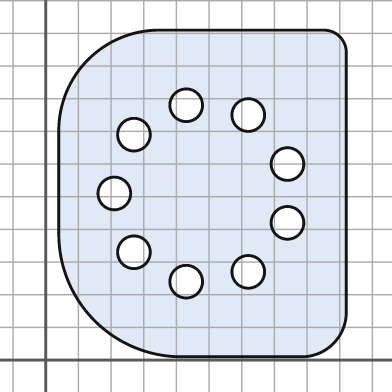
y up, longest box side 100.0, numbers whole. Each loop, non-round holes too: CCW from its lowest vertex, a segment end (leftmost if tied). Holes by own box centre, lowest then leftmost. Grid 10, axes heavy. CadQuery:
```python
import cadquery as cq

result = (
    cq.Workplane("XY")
    .moveTo(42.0, 1.0)
    .lineTo(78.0, 1.0)
    .threePointArc((88.0, 5.0), (92.0, 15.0))
    .lineTo(92.0, 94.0)
    .threePointArc((90.0, 99.0), (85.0, 101.0))
    .lineTo(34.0, 101.0)
    .threePointArc((13.0, 92.0), (4.0, 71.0))
    .lineTo(4.0, 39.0)
    .threePointArc((15.0, 12.0), (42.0, 1.0))
    .close()
    .moveTo(43.0, 24.0)
    .circle(5.0)
    .moveTo(62.0, 27.0)
    .circle(5.0)
    .moveTo(27.0, 33.0)
    .circle(5.0)
    .moveTo(74.0, 42.0)
    .circle(5.0)
    .moveTo(21.0, 51.0)
    .circle(5.0)
    .moveTo(74.0, 60.0)
    .circle(5.0)
    .moveTo(27.0, 69.0)
    .circle(5.0)
    .moveTo(62.0, 75.0)
    .circle(5.0)
    .moveTo(43.0, 78.0)
    .circle(5.0)
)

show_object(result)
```